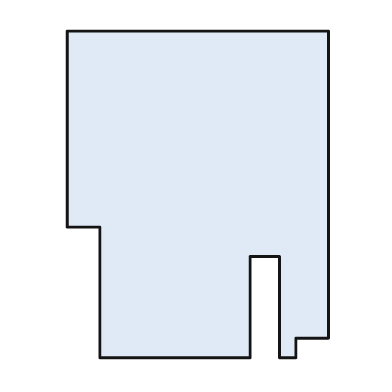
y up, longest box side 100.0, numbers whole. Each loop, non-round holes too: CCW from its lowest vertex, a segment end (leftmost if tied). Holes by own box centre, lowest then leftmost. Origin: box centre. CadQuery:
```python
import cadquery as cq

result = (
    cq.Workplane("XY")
    .moveTo(-30.0, -50.0)
    .lineTo(16.0, -50.0)
    .lineTo(16.0, -19.0)
    .lineTo(25.0, -19.0)
    .lineTo(25.0, -50.0)
    .lineTo(30.0, -50.0)
    .lineTo(30.0, -44.0)
    .lineTo(40.0, -44.0)
    .lineTo(40.0, 50.0)
    .lineTo(-40.0, 50.0)
    .lineTo(-40.0, -10.0)
    .lineTo(-30.0, -10.0)
    .close()
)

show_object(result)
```